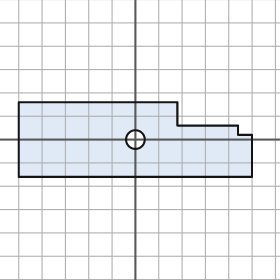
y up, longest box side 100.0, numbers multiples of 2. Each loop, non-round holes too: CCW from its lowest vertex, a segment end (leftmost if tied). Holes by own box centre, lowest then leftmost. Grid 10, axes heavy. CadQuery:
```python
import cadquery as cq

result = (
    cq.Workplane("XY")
    .moveTo(-50.0, -16.0)
    .lineTo(50.0, -16.0)
    .lineTo(50.0, 2.0)
    .lineTo(44.0, 2.0)
    .lineTo(44.0, 6.0)
    .lineTo(18.0, 6.0)
    .lineTo(18.0, 16.0)
    .lineTo(-50.0, 16.0)
    .close()
    .moveTo(0.0, 0.0)
    .circle(4.0)
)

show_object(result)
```